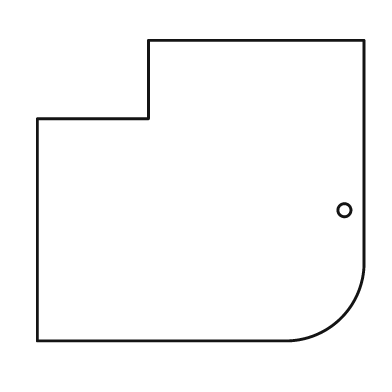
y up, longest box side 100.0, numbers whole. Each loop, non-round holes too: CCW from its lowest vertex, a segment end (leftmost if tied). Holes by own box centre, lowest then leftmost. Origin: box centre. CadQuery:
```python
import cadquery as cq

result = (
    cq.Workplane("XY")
    .moveTo(-50.0, -46.0)
    .lineTo(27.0, -46.0)
    .threePointArc((43.0, -39.0), (50.0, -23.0))
    .lineTo(50.0, 46.0)
    .lineTo(-16.0, 46.0)
    .lineTo(-16.0, 22.0)
    .lineTo(-50.0, 22.0)
    .close()
    .moveTo(44.0, -6.0)
    .circle(2.0)
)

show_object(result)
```